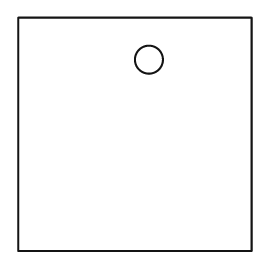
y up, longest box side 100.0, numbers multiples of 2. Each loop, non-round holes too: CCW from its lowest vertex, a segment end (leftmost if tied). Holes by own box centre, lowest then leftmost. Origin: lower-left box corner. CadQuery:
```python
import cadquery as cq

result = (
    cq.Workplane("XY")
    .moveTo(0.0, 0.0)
    .lineTo(100.0, 0.0)
    .lineTo(100.0, 100.0)
    .lineTo(0.0, 100.0)
    .close()
    .moveTo(56.0, 82.0)
    .circle(6.0)
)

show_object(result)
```